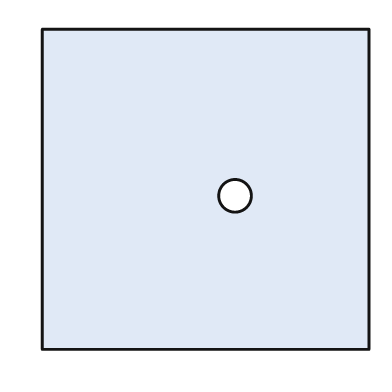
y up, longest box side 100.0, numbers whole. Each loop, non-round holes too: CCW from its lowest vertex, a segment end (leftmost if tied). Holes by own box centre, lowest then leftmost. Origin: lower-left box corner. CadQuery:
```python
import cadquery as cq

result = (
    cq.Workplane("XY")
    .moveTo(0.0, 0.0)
    .lineTo(100.0, 0.0)
    .lineTo(100.0, 98.0)
    .lineTo(0.0, 98.0)
    .close()
    .moveTo(59.0, 47.0)
    .circle(5.0)
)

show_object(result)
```